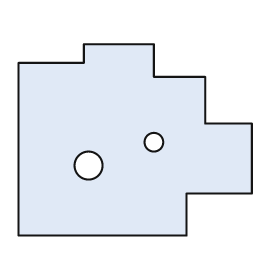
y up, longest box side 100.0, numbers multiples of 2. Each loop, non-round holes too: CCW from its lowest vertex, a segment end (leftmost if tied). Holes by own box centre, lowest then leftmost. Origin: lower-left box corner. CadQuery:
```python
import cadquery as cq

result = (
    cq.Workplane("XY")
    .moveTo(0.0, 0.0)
    .lineTo(72.0, 0.0)
    .lineTo(72.0, 18.0)
    .lineTo(100.0, 18.0)
    .lineTo(100.0, 48.0)
    .lineTo(80.0, 48.0)
    .lineTo(80.0, 68.0)
    .lineTo(58.0, 68.0)
    .lineTo(58.0, 82.0)
    .lineTo(28.0, 82.0)
    .lineTo(28.0, 74.0)
    .lineTo(0.0, 74.0)
    .close()
    .moveTo(30.0, 30.0)
    .circle(6.0)
    .moveTo(58.0, 40.0)
    .circle(4.0)
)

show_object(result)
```